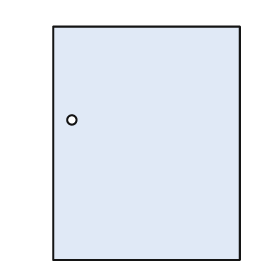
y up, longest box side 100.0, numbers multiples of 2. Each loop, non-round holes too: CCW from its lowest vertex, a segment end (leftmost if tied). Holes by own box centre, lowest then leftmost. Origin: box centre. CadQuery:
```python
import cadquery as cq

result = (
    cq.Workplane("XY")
    .moveTo(-40.0, -50.0)
    .lineTo(40.0, -50.0)
    .lineTo(40.0, 50.0)
    .lineTo(-40.0, 50.0)
    .close()
    .moveTo(-32.0, 10.0)
    .circle(2.0)
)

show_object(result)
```